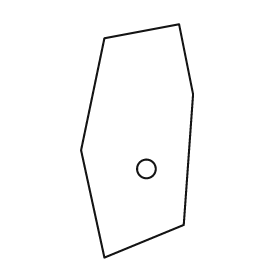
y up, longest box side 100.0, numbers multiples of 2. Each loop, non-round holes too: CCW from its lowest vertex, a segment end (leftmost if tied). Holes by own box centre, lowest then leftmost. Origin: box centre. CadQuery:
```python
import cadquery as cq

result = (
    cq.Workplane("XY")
    .moveTo(-14.0, -50.0)
    .lineTo(20.0, -36.0)
    .lineTo(24.0, 20.0)
    .lineTo(18.0, 50.0)
    .lineTo(-14.0, 44.0)
    .lineTo(-24.0, -4.0)
    .close()
    .moveTo(4.0, -12.0)
    .circle(4.0)
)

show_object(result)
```